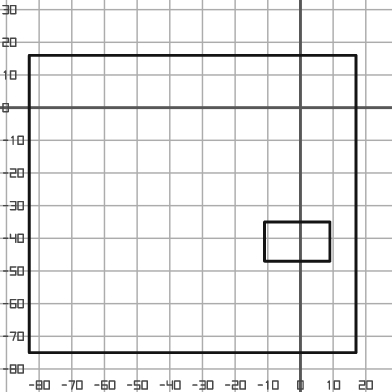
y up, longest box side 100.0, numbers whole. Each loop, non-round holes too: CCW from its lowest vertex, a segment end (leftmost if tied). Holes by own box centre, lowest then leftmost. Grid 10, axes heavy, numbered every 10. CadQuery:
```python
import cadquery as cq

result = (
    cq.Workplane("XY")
    .moveTo(-83.0, -75.0)
    .lineTo(17.0, -75.0)
    .lineTo(17.0, 16.0)
    .lineTo(-83.0, 16.0)
    .close()
    .moveTo(-11.0, -47.0)
    .lineTo(9.0, -47.0)
    .lineTo(9.0, -35.0)
    .lineTo(-11.0, -35.0)
    .close()
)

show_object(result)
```